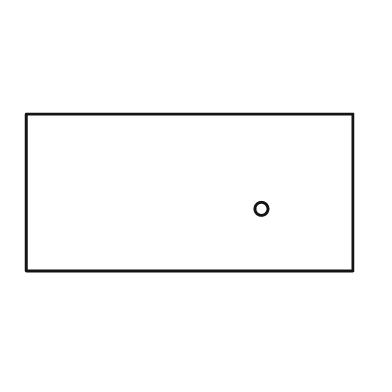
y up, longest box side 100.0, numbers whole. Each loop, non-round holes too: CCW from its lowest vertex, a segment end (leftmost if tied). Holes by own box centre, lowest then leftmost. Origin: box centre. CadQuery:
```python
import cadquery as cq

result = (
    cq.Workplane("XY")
    .moveTo(-50.0, -24.0)
    .lineTo(50.0, -24.0)
    .lineTo(50.0, 24.0)
    .lineTo(-50.0, 24.0)
    .close()
    .moveTo(22.0, -5.0)
    .circle(2.0)
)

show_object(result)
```